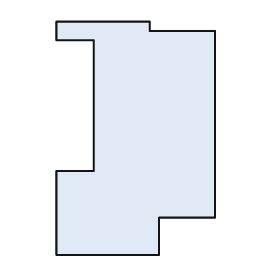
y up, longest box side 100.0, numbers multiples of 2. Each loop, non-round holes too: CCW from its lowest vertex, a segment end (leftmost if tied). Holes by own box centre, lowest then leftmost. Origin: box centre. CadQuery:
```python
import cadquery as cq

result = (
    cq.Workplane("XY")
    .moveTo(-34.0, -50.0)
    .lineTo(10.0, -50.0)
    .lineTo(10.0, -34.0)
    .lineTo(34.0, -34.0)
    .lineTo(34.0, 46.0)
    .lineTo(6.0, 46.0)
    .lineTo(6.0, 50.0)
    .lineTo(-34.0, 50.0)
    .lineTo(-34.0, 42.0)
    .lineTo(-18.0, 42.0)
    .lineTo(-18.0, -14.0)
    .lineTo(-34.0, -14.0)
    .close()
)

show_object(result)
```